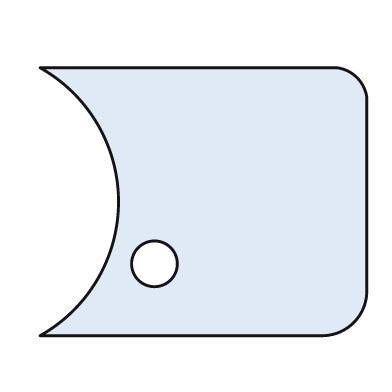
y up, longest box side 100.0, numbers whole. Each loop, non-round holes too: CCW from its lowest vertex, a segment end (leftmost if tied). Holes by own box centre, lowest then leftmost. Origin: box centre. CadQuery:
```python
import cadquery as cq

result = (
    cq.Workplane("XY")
    .moveTo(-50.0, -41.0)
    .lineTo(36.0, -41.0)
    .threePointArc((46.0, -37.0), (50.0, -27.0))
    .lineTo(50.0, 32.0)
    .threePointArc((47.0, 38.0), (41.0, 41.0))
    .lineTo(-50.0, 41.0)
    .threePointArc((-26.0, 0.0), (-50.0, -41.0))
    .close()
    .moveTo(-15.0, -19.0)
    .circle(7.0)
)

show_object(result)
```